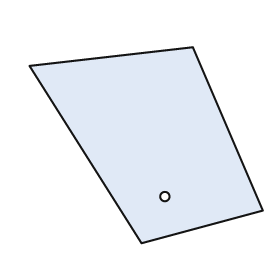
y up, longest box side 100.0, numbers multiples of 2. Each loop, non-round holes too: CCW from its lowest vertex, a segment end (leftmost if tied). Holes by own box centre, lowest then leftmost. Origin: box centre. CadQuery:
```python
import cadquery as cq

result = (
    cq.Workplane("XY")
    .moveTo(-2.0, -42.0)
    .lineTo(50.0, -28.0)
    .lineTo(20.0, 42.0)
    .lineTo(-50.0, 34.0)
    .close()
    .moveTo(8.0, -22.0)
    .circle(2.0)
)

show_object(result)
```